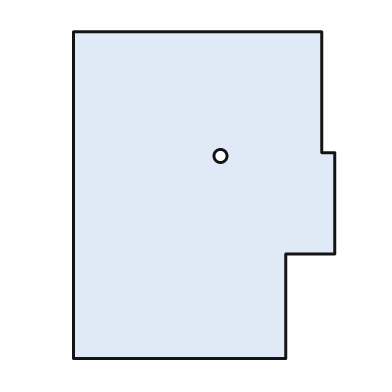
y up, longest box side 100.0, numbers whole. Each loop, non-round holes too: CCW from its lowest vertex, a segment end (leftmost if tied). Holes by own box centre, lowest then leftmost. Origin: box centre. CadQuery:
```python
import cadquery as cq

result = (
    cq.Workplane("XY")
    .moveTo(-40.0, -50.0)
    .lineTo(25.0, -50.0)
    .lineTo(25.0, -18.0)
    .lineTo(40.0, -18.0)
    .lineTo(40.0, 13.0)
    .lineTo(36.0, 13.0)
    .lineTo(36.0, 50.0)
    .lineTo(-40.0, 50.0)
    .close()
    .moveTo(5.0, 12.0)
    .circle(2.0)
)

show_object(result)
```